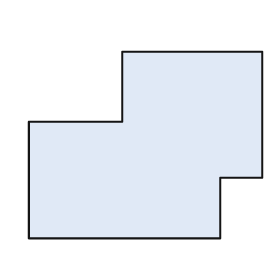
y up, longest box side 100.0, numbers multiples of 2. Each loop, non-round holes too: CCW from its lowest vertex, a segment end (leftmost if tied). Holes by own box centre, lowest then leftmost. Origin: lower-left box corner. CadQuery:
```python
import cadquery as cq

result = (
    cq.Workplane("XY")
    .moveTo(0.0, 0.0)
    .lineTo(82.0, 0.0)
    .lineTo(82.0, 26.0)
    .lineTo(100.0, 26.0)
    .lineTo(100.0, 80.0)
    .lineTo(40.0, 80.0)
    .lineTo(40.0, 50.0)
    .lineTo(0.0, 50.0)
    .close()
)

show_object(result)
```